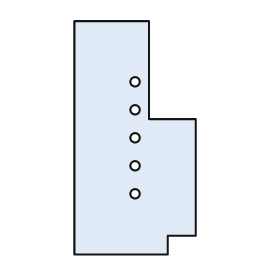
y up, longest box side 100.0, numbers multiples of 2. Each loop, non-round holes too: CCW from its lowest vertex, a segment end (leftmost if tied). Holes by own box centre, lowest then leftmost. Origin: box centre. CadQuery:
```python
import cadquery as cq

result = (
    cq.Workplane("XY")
    .moveTo(-26.0, -50.0)
    .lineTo(14.0, -50.0)
    .lineTo(14.0, -42.0)
    .lineTo(26.0, -42.0)
    .lineTo(26.0, 8.0)
    .lineTo(6.0, 8.0)
    .lineTo(6.0, 50.0)
    .lineTo(-26.0, 50.0)
    .close()
    .moveTo(0.0, -24.0)
    .circle(2.0)
    .moveTo(0.0, -12.0)
    .circle(2.0)
    .moveTo(0.0, 0.0)
    .circle(2.0)
    .moveTo(0.0, 12.0)
    .circle(2.0)
    .moveTo(0.0, 24.0)
    .circle(2.0)
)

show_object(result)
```